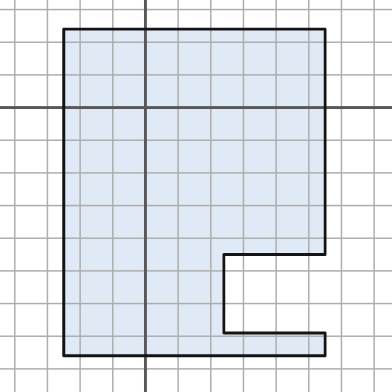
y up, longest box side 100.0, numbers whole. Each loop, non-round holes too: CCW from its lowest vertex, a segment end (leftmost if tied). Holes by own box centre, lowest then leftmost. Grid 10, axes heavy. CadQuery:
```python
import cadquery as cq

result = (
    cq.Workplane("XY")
    .moveTo(-25.0, -76.0)
    .lineTo(55.0, -76.0)
    .lineTo(55.0, -69.0)
    .lineTo(24.0, -69.0)
    .lineTo(24.0, -45.0)
    .lineTo(55.0, -45.0)
    .lineTo(55.0, 24.0)
    .lineTo(-25.0, 24.0)
    .close()
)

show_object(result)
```